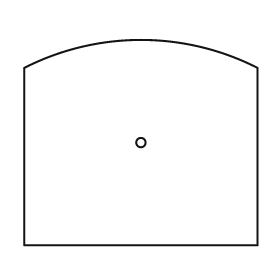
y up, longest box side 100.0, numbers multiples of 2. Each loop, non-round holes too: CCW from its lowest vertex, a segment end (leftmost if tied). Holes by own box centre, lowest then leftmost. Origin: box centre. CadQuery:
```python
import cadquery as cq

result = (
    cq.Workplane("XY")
    .moveTo(-50.0, -44.0)
    .lineTo(50.0, -44.0)
    .lineTo(50.0, 32.0)
    .threePointArc((0.0, 44.0), (-50.0, 32.0))
    .close()
    .moveTo(0.0, 0.0)
    .circle(2.0)
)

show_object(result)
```